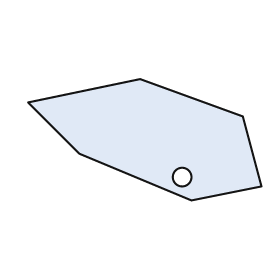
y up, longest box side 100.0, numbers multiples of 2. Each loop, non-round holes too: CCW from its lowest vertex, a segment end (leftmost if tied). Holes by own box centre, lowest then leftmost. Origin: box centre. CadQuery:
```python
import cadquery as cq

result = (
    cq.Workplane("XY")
    .moveTo(20.0, -26.0)
    .lineTo(50.0, -20.0)
    .lineTo(42.0, 10.0)
    .lineTo(-2.0, 26.0)
    .lineTo(-50.0, 16.0)
    .lineTo(-28.0, -6.0)
    .close()
    .moveTo(16.0, -16.0)
    .circle(4.0)
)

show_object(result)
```